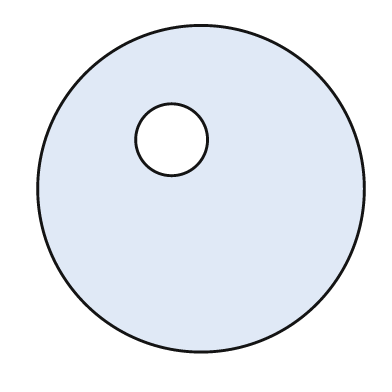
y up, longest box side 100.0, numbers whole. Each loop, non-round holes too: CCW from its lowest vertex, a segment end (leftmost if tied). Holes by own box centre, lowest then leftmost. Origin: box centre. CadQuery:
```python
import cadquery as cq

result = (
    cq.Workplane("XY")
    .moveTo(0.0, 0.0)
    .circle(50.0)
    .moveTo(-9.0, 15.0)
    .circle(11.0)
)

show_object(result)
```